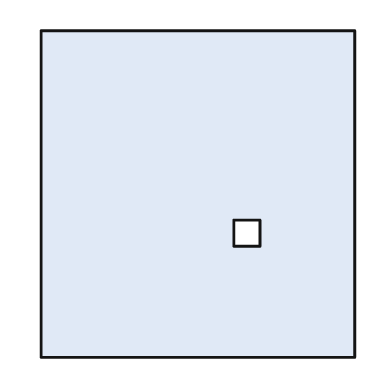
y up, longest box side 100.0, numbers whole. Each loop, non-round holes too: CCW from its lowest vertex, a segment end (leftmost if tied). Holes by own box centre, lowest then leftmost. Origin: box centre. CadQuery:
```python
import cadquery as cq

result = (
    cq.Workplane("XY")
    .moveTo(-48.0, -50.0)
    .lineTo(48.0, -50.0)
    .lineTo(48.0, 50.0)
    .lineTo(-48.0, 50.0)
    .close()
    .moveTo(11.0, -16.0)
    .lineTo(19.0, -16.0)
    .lineTo(19.0, -8.0)
    .lineTo(11.0, -8.0)
    .close()
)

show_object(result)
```